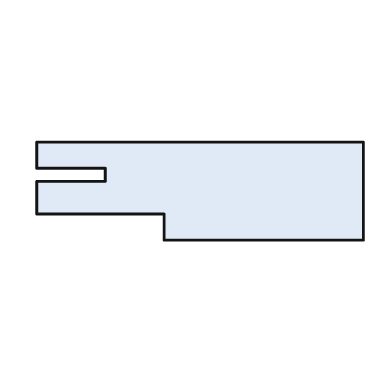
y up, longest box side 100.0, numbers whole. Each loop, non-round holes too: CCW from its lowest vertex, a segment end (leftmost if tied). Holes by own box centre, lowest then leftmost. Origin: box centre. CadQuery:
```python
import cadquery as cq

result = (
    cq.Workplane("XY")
    .moveTo(-11.0, -15.0)
    .lineTo(50.0, -15.0)
    .lineTo(50.0, 15.0)
    .lineTo(-50.0, 15.0)
    .lineTo(-50.0, 7.0)
    .lineTo(-29.0, 7.0)
    .lineTo(-29.0, 3.0)
    .lineTo(-50.0, 3.0)
    .lineTo(-50.0, -7.0)
    .lineTo(-11.0, -7.0)
    .close()
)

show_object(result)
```